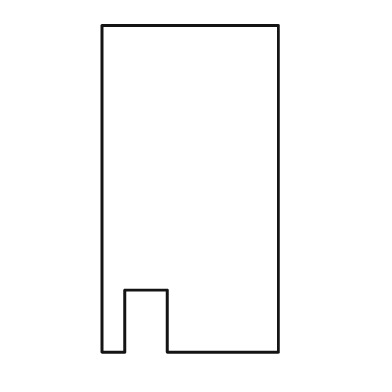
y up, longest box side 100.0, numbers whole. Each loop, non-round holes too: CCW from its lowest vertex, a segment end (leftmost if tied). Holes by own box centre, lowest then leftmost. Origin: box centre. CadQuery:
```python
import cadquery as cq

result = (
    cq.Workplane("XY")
    .moveTo(-27.0, -50.0)
    .lineTo(-20.0, -50.0)
    .lineTo(-20.0, -31.0)
    .lineTo(-7.0, -31.0)
    .lineTo(-7.0, -50.0)
    .lineTo(27.0, -50.0)
    .lineTo(27.0, 50.0)
    .lineTo(-27.0, 50.0)
    .close()
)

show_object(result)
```